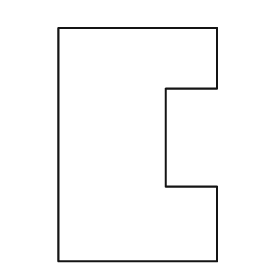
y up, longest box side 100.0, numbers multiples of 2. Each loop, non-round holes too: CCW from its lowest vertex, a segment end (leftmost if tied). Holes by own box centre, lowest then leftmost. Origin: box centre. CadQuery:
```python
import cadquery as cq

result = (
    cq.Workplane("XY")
    .moveTo(-34.0, -50.0)
    .lineTo(34.0, -50.0)
    .lineTo(34.0, -18.0)
    .lineTo(12.0, -18.0)
    .lineTo(12.0, 24.0)
    .lineTo(34.0, 24.0)
    .lineTo(34.0, 50.0)
    .lineTo(-34.0, 50.0)
    .close()
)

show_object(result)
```